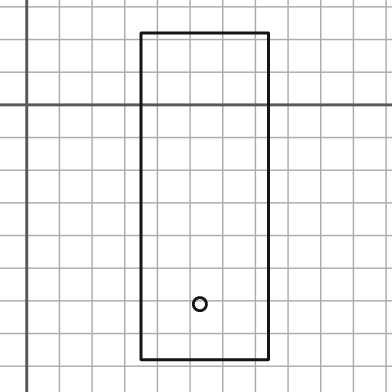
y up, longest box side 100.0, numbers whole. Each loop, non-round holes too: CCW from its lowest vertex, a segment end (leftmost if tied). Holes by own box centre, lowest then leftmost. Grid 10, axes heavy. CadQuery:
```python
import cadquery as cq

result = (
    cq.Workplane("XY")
    .moveTo(35.0, -78.0)
    .lineTo(74.0, -78.0)
    .lineTo(74.0, 22.0)
    .lineTo(35.0, 22.0)
    .close()
    .moveTo(53.0, -61.0)
    .circle(2.0)
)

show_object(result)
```